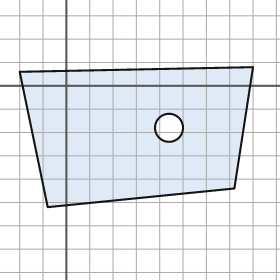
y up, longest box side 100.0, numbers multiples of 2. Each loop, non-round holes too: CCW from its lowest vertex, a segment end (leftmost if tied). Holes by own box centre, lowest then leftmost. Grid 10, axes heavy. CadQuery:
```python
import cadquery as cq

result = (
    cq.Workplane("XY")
    .moveTo(-8.0, -52.0)
    .lineTo(72.0, -44.0)
    .lineTo(80.0, 8.0)
    .lineTo(-20.0, 6.0)
    .close()
    .moveTo(44.0, -18.0)
    .circle(6.0)
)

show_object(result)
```